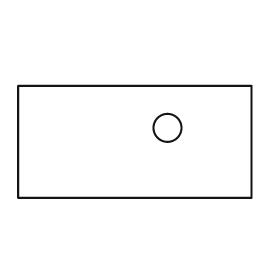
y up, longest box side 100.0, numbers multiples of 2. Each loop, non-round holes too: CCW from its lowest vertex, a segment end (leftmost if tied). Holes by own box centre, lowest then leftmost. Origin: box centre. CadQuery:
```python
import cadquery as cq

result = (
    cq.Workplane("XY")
    .moveTo(-50.0, -24.0)
    .lineTo(50.0, -24.0)
    .lineTo(50.0, 24.0)
    .lineTo(-50.0, 24.0)
    .close()
    .moveTo(14.0, 6.0)
    .circle(6.0)
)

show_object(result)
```